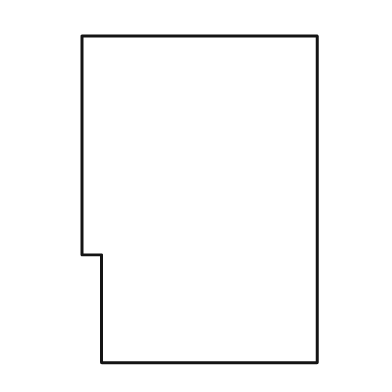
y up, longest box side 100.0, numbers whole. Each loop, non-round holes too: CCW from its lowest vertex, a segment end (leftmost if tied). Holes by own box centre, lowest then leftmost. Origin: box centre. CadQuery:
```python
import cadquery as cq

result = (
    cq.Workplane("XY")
    .moveTo(-30.0, -50.0)
    .lineTo(36.0, -50.0)
    .lineTo(36.0, 50.0)
    .lineTo(-36.0, 50.0)
    .lineTo(-36.0, -17.0)
    .lineTo(-30.0, -17.0)
    .close()
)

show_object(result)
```